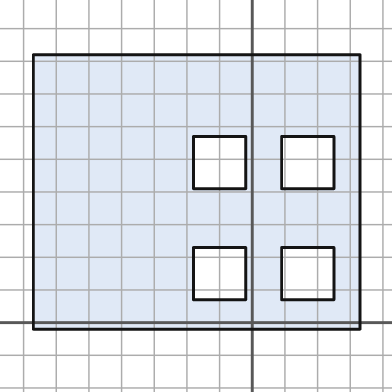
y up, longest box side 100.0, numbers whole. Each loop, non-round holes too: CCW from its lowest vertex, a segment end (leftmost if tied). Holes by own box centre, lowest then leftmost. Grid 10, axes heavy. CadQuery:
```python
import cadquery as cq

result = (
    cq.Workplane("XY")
    .moveTo(-67.0, -2.0)
    .lineTo(33.0, -2.0)
    .lineTo(33.0, 82.0)
    .lineTo(-67.0, 82.0)
    .close()
    .moveTo(-18.0, 7.0)
    .lineTo(-2.0, 7.0)
    .lineTo(-2.0, 23.0)
    .lineTo(-18.0, 23.0)
    .close()
    .moveTo(9.0, 7.0)
    .lineTo(25.0, 7.0)
    .lineTo(25.0, 23.0)
    .lineTo(9.0, 23.0)
    .close()
    .moveTo(-18.0, 41.0)
    .lineTo(-2.0, 41.0)
    .lineTo(-2.0, 57.0)
    .lineTo(-18.0, 57.0)
    .close()
    .moveTo(9.0, 41.0)
    .lineTo(25.0, 41.0)
    .lineTo(25.0, 57.0)
    .lineTo(9.0, 57.0)
    .close()
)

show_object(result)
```